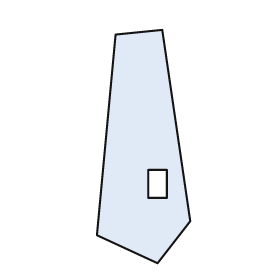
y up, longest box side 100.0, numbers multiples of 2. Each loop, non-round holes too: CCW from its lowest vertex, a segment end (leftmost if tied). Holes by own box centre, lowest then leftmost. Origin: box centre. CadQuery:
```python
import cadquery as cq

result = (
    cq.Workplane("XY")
    .moveTo(6.0, -50.0)
    .lineTo(20.0, -32.0)
    .lineTo(8.0, 50.0)
    .lineTo(-12.0, 48.0)
    .lineTo(-20.0, -38.0)
    .close()
    .moveTo(2.0, -22.0)
    .lineTo(10.0, -22.0)
    .lineTo(10.0, -10.0)
    .lineTo(2.0, -10.0)
    .close()
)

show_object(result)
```